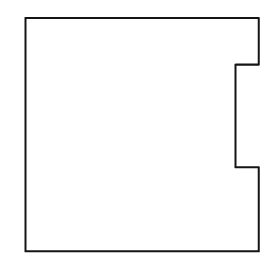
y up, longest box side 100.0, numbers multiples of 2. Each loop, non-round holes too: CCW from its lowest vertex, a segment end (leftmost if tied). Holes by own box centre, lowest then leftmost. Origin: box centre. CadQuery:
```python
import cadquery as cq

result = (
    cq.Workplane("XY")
    .moveTo(-50.0, -50.0)
    .lineTo(50.0, -50.0)
    .lineTo(50.0, -14.0)
    .lineTo(40.0, -14.0)
    .lineTo(40.0, 30.0)
    .lineTo(50.0, 30.0)
    .lineTo(50.0, 50.0)
    .lineTo(-50.0, 50.0)
    .close()
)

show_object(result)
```